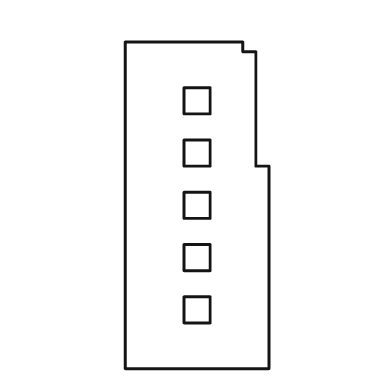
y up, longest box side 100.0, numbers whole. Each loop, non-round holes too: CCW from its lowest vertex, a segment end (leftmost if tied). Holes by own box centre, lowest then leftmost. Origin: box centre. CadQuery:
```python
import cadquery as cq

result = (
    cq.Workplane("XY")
    .moveTo(-22.0, -50.0)
    .lineTo(22.0, -50.0)
    .lineTo(22.0, 12.0)
    .lineTo(18.0, 12.0)
    .lineTo(18.0, 47.0)
    .lineTo(14.0, 47.0)
    .lineTo(14.0, 50.0)
    .lineTo(-22.0, 50.0)
    .close()
    .moveTo(-4.0, -36.0)
    .lineTo(4.0, -36.0)
    .lineTo(4.0, -28.0)
    .lineTo(-4.0, -28.0)
    .close()
    .moveTo(-4.0, -20.0)
    .lineTo(4.0, -20.0)
    .lineTo(4.0, -12.0)
    .lineTo(-4.0, -12.0)
    .close()
    .moveTo(-4.0, -4.0)
    .lineTo(4.0, -4.0)
    .lineTo(4.0, 4.0)
    .lineTo(-4.0, 4.0)
    .close()
    .moveTo(-4.0, 12.0)
    .lineTo(4.0, 12.0)
    .lineTo(4.0, 20.0)
    .lineTo(-4.0, 20.0)
    .close()
    .moveTo(-4.0, 28.0)
    .lineTo(4.0, 28.0)
    .lineTo(4.0, 36.0)
    .lineTo(-4.0, 36.0)
    .close()
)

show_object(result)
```